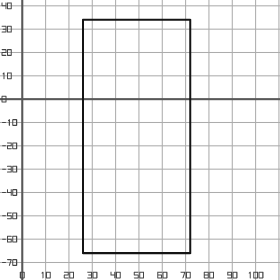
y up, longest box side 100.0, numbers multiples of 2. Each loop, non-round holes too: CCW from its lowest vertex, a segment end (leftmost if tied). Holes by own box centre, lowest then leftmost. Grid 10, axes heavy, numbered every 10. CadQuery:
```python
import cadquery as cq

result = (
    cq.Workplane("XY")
    .moveTo(26.0, -66.0)
    .lineTo(72.0, -66.0)
    .lineTo(72.0, 34.0)
    .lineTo(26.0, 34.0)
    .close()
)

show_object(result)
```